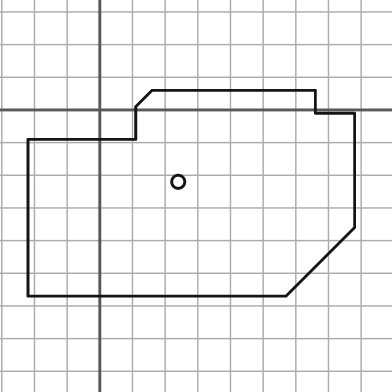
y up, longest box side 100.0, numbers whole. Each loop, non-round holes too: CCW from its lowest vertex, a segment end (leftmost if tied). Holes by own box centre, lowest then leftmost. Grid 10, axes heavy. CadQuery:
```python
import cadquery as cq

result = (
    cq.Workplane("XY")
    .moveTo(-22.0, -57.0)
    .lineTo(57.0, -57.0)
    .lineTo(78.0, -36.0)
    .lineTo(78.0, -1.0)
    .lineTo(66.0, -1.0)
    .lineTo(66.0, 6.0)
    .lineTo(16.0, 6.0)
    .lineTo(11.0, 1.0)
    .lineTo(11.0, -9.0)
    .lineTo(-22.0, -9.0)
    .close()
    .moveTo(24.0, -22.0)
    .circle(2.0)
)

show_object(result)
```